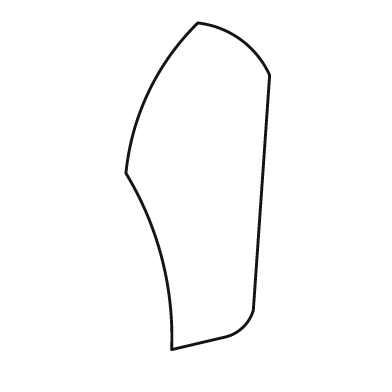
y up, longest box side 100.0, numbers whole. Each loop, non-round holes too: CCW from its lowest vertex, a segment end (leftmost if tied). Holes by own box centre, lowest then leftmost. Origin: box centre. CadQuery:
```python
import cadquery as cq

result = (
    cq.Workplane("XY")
    .moveTo(-8.0, -50.0)
    .lineTo(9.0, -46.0)
    .threePointArc((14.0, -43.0), (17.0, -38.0))
    .lineTo(22.0, 34.0)
    .threePointArc((13.0, 45.0), (0.0, 50.0))
    .threePointArc((-15.0, 29.0), (-22.0, 4.0))
    .threePointArc((-11.0, -22.0), (-8.0, -50.0))
    .close()
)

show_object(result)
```